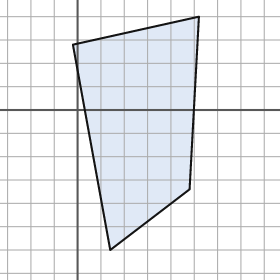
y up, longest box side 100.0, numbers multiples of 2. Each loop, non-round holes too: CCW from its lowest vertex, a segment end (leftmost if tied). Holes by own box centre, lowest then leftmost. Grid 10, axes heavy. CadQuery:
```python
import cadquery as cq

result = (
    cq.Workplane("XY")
    .moveTo(14.0, -60.0)
    .lineTo(48.0, -34.0)
    .lineTo(52.0, 40.0)
    .lineTo(-2.0, 28.0)
    .close()
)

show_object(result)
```